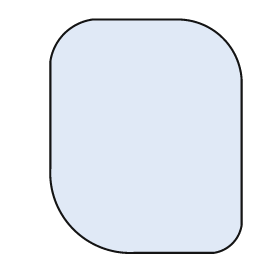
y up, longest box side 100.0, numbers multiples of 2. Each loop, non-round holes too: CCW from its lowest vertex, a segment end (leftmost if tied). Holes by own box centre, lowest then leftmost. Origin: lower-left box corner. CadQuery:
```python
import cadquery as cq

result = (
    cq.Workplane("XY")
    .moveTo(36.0, 0.0)
    .lineTo(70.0, 0.0)
    .threePointArc((78.0, 4.0), (82.0, 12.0))
    .lineTo(82.0, 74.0)
    .threePointArc((74.0, 92.0), (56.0, 100.0))
    .lineTo(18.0, 100.0)
    .threePointArc((6.0, 94.0), (0.0, 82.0))
    .lineTo(0.0, 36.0)
    .threePointArc((10.0, 10.0), (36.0, 0.0))
    .close()
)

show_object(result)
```